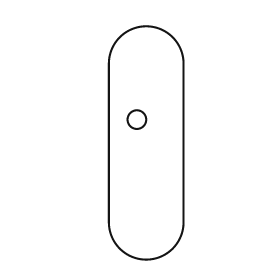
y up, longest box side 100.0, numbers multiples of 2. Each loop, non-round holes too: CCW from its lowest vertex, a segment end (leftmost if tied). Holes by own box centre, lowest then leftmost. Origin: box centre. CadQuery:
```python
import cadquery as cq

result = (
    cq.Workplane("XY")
    .moveTo(-16.0, -34.0)
    .threePointArc((0.0, -50.0), (16.0, -34.0))
    .lineTo(16.0, 34.0)
    .threePointArc((0.0, 50.0), (-16.0, 34.0))
    .close()
    .moveTo(-4.0, 10.0)
    .circle(4.0)
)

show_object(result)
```